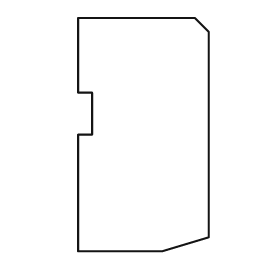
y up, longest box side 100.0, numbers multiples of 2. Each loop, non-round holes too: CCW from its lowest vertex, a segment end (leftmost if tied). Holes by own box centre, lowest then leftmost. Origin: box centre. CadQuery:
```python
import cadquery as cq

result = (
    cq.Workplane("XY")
    .moveTo(-28.0, -50.0)
    .lineTo(8.0, -50.0)
    .lineTo(28.0, -44.0)
    .lineTo(28.0, 44.0)
    .lineTo(22.0, 50.0)
    .lineTo(-28.0, 50.0)
    .lineTo(-28.0, 18.0)
    .lineTo(-22.0, 18.0)
    .lineTo(-22.0, 0.0)
    .lineTo(-28.0, 0.0)
    .close()
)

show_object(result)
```